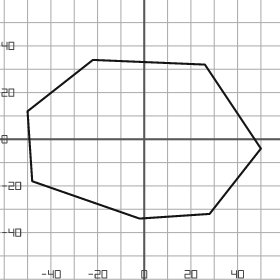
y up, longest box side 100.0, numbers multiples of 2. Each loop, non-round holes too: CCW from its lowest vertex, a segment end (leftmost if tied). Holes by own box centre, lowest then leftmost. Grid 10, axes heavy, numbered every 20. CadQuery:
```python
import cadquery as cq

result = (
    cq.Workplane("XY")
    .moveTo(-2.0, -34.0)
    .lineTo(28.0, -32.0)
    .lineTo(50.0, -4.0)
    .lineTo(26.0, 32.0)
    .lineTo(-22.0, 34.0)
    .lineTo(-50.0, 12.0)
    .lineTo(-48.0, -18.0)
    .close()
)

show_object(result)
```